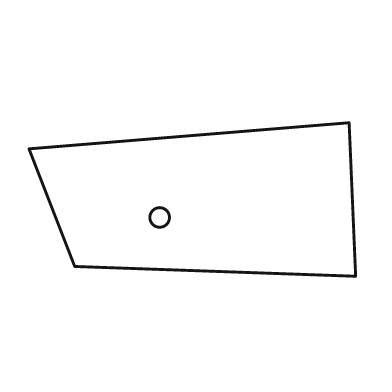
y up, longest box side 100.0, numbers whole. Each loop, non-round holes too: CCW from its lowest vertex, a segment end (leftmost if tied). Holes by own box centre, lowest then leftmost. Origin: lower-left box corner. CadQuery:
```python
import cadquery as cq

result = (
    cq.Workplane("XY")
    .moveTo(100.0, 0.0)
    .lineTo(98.0, 47.0)
    .lineTo(0.0, 39.0)
    .lineTo(14.0, 3.0)
    .close()
    .moveTo(40.0, 18.0)
    .circle(3.0)
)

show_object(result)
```